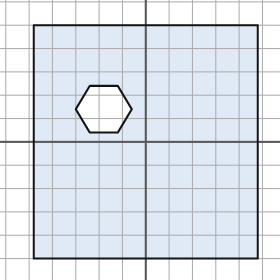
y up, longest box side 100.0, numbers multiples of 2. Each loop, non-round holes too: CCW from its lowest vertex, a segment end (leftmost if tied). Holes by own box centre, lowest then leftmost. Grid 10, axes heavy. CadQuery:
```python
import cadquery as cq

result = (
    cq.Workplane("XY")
    .moveTo(-48.0, -50.0)
    .lineTo(48.0, -50.0)
    .lineTo(48.0, 50.0)
    .lineTo(-48.0, 50.0)
    .close()
    .moveTo(-24.0, 4.0)
    .lineTo(-12.0, 4.0)
    .lineTo(-6.0, 14.0)
    .lineTo(-12.0, 24.0)
    .lineTo(-24.0, 24.0)
    .lineTo(-30.0, 14.0)
    .close()
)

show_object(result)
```